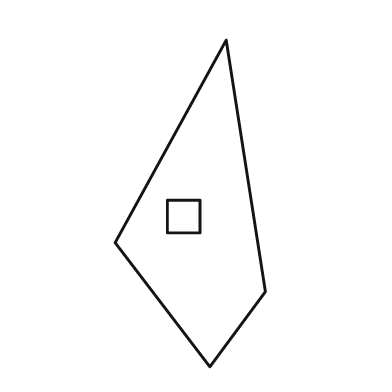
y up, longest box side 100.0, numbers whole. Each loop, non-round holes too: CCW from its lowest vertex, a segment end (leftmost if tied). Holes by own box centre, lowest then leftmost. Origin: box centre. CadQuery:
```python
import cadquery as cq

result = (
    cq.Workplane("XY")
    .moveTo(6.0, -50.0)
    .lineTo(23.0, -27.0)
    .lineTo(11.0, 50.0)
    .lineTo(-23.0, -12.0)
    .close()
    .moveTo(-7.0, -9.0)
    .lineTo(3.0, -9.0)
    .lineTo(3.0, 1.0)
    .lineTo(-7.0, 1.0)
    .close()
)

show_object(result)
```